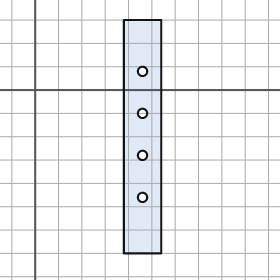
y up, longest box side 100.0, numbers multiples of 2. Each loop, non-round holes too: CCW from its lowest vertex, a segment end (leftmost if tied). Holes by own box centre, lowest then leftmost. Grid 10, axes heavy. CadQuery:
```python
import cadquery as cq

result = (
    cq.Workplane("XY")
    .moveTo(38.0, -70.0)
    .lineTo(54.0, -70.0)
    .lineTo(54.0, 30.0)
    .lineTo(38.0, 30.0)
    .close()
    .moveTo(46.0, -46.0)
    .circle(2.0)
    .moveTo(46.0, -28.0)
    .circle(2.0)
    .moveTo(46.0, -10.0)
    .circle(2.0)
    .moveTo(46.0, 8.0)
    .circle(2.0)
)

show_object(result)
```